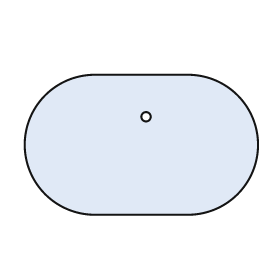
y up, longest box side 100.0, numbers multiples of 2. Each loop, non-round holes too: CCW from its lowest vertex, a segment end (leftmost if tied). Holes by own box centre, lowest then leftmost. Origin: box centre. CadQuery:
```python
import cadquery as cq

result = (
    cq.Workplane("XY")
    .moveTo(-20.0, -30.0)
    .lineTo(20.0, -30.0)
    .threePointArc((50.0, 0.0), (20.0, 30.0))
    .lineTo(-20.0, 30.0)
    .threePointArc((-50.0, 0.0), (-20.0, -30.0))
    .close()
    .moveTo(2.0, 12.0)
    .circle(2.0)
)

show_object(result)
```